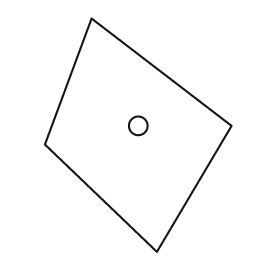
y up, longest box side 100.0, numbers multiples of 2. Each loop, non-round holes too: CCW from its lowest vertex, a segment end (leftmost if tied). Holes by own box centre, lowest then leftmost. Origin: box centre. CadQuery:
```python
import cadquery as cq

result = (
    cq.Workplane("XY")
    .moveTo(8.0, -50.0)
    .lineTo(40.0, 4.0)
    .lineTo(-20.0, 50.0)
    .lineTo(-40.0, -4.0)
    .close()
    .moveTo(0.0, 4.0)
    .circle(4.0)
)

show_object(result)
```